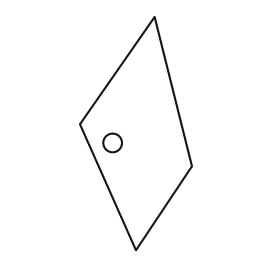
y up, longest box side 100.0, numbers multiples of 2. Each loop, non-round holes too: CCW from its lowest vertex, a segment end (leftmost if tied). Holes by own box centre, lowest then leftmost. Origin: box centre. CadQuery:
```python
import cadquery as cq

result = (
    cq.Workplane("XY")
    .moveTo(0.0, -50.0)
    .lineTo(24.0, -14.0)
    .lineTo(8.0, 50.0)
    .lineTo(-24.0, 4.0)
    .close()
    .moveTo(-10.0, -4.0)
    .circle(4.0)
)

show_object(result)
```